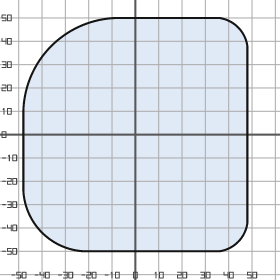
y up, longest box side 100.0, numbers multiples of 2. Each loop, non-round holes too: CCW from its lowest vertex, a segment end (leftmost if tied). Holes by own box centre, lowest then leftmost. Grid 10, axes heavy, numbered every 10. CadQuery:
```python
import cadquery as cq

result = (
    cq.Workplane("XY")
    .moveTo(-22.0, -50.0)
    .lineTo(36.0, -50.0)
    .threePointArc((44.0, -46.0), (48.0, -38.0))
    .lineTo(48.0, 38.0)
    .threePointArc((44.0, 46.0), (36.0, 50.0))
    .lineTo(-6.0, 50.0)
    .threePointArc((-36.0, 38.0), (-48.0, 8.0))
    .lineTo(-48.0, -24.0)
    .threePointArc((-40.0, -42.0), (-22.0, -50.0))
    .close()
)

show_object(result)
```